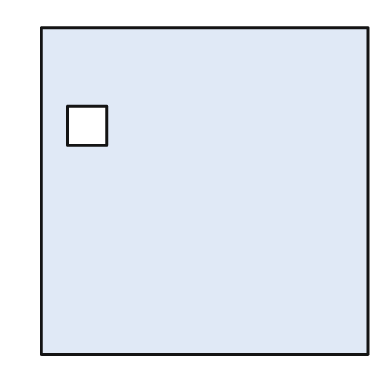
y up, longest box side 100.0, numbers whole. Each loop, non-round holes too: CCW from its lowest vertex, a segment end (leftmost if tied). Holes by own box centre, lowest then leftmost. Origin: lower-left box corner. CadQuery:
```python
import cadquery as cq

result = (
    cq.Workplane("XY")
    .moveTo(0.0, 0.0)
    .lineTo(100.0, 0.0)
    .lineTo(100.0, 100.0)
    .lineTo(0.0, 100.0)
    .close()
    .moveTo(8.0, 64.0)
    .lineTo(20.0, 64.0)
    .lineTo(20.0, 76.0)
    .lineTo(8.0, 76.0)
    .close()
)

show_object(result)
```